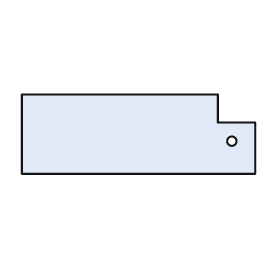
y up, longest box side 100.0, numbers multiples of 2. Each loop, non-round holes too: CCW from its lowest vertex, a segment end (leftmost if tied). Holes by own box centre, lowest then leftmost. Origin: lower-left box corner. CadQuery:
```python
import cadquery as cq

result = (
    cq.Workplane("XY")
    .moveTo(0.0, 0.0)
    .lineTo(100.0, 0.0)
    .lineTo(100.0, 22.0)
    .lineTo(84.0, 22.0)
    .lineTo(84.0, 34.0)
    .lineTo(0.0, 34.0)
    .close()
    .moveTo(90.0, 14.0)
    .circle(2.0)
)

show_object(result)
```